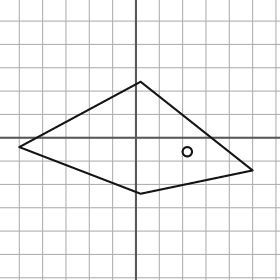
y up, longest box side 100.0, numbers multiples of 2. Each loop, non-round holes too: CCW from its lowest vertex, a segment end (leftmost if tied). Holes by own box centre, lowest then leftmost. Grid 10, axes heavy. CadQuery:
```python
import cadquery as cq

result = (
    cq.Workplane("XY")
    .moveTo(2.0, -24.0)
    .lineTo(50.0, -14.0)
    .lineTo(2.0, 24.0)
    .lineTo(-50.0, -4.0)
    .close()
    .moveTo(22.0, -6.0)
    .circle(2.0)
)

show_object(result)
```